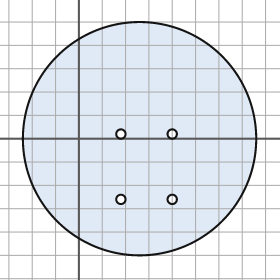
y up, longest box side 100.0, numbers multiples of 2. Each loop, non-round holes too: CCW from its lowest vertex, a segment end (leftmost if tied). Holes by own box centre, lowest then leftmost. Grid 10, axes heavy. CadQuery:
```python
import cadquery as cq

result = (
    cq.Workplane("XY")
    .moveTo(26.0, 0.0)
    .circle(50.0)
    .moveTo(18.0, -26.0)
    .circle(2.0)
    .moveTo(40.0, -26.0)
    .circle(2.0)
    .moveTo(18.0, 2.0)
    .circle(2.0)
    .moveTo(40.0, 2.0)
    .circle(2.0)
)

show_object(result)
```